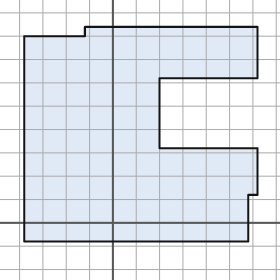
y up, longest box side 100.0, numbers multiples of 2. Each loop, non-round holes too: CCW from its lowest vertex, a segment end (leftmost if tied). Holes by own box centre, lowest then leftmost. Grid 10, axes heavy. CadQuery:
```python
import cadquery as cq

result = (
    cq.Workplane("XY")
    .moveTo(-38.0, -8.0)
    .lineTo(58.0, -8.0)
    .lineTo(58.0, 12.0)
    .lineTo(62.0, 12.0)
    .lineTo(62.0, 32.0)
    .lineTo(20.0, 32.0)
    .lineTo(20.0, 62.0)
    .lineTo(62.0, 62.0)
    .lineTo(62.0, 84.0)
    .lineTo(-12.0, 84.0)
    .lineTo(-12.0, 80.0)
    .lineTo(-38.0, 80.0)
    .close()
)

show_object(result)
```